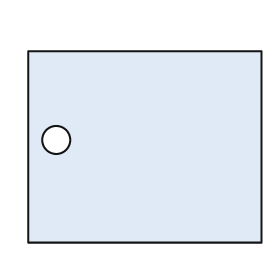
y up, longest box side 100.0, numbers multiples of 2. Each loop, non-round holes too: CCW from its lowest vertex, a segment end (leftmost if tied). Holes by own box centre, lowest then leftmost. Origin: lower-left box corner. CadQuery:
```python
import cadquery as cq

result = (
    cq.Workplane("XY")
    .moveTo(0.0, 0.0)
    .lineTo(100.0, 0.0)
    .lineTo(100.0, 82.0)
    .lineTo(0.0, 82.0)
    .close()
    .moveTo(12.0, 44.0)
    .circle(6.0)
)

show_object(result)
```